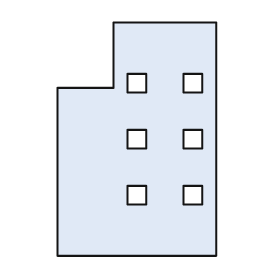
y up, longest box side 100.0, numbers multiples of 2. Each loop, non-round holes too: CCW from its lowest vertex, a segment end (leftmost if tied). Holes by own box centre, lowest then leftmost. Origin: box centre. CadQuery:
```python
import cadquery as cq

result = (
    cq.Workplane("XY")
    .moveTo(-34.0, -50.0)
    .lineTo(34.0, -50.0)
    .lineTo(34.0, 50.0)
    .lineTo(-10.0, 50.0)
    .lineTo(-10.0, 22.0)
    .lineTo(-34.0, 22.0)
    .close()
    .moveTo(-4.0, -28.0)
    .lineTo(4.0, -28.0)
    .lineTo(4.0, -20.0)
    .lineTo(-4.0, -20.0)
    .close()
    .moveTo(20.0, -28.0)
    .lineTo(28.0, -28.0)
    .lineTo(28.0, -20.0)
    .lineTo(20.0, -20.0)
    .close()
    .moveTo(-4.0, -4.0)
    .lineTo(4.0, -4.0)
    .lineTo(4.0, 4.0)
    .lineTo(-4.0, 4.0)
    .close()
    .moveTo(20.0, -4.0)
    .lineTo(28.0, -4.0)
    .lineTo(28.0, 4.0)
    .lineTo(20.0, 4.0)
    .close()
    .moveTo(-4.0, 20.0)
    .lineTo(4.0, 20.0)
    .lineTo(4.0, 28.0)
    .lineTo(-4.0, 28.0)
    .close()
    .moveTo(20.0, 20.0)
    .lineTo(28.0, 20.0)
    .lineTo(28.0, 28.0)
    .lineTo(20.0, 28.0)
    .close()
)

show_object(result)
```